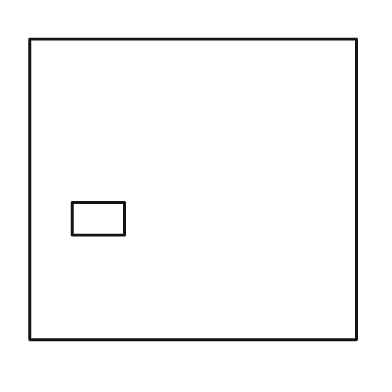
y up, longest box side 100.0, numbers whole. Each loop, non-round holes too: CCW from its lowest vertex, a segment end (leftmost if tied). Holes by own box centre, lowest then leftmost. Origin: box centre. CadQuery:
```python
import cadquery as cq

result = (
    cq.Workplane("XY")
    .moveTo(-50.0, -46.0)
    .lineTo(50.0, -46.0)
    .lineTo(50.0, 46.0)
    .lineTo(-50.0, 46.0)
    .close()
    .moveTo(-37.0, -14.0)
    .lineTo(-21.0, -14.0)
    .lineTo(-21.0, -4.0)
    .lineTo(-37.0, -4.0)
    .close()
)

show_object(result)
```